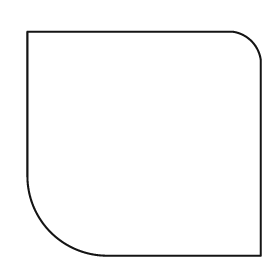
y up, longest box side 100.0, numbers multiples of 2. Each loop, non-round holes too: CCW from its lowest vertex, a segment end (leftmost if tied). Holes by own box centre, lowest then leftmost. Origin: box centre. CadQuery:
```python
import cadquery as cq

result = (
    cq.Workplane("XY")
    .moveTo(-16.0, -48.0)
    .lineTo(50.0, -48.0)
    .lineTo(50.0, 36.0)
    .threePointArc((46.0, 44.0), (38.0, 48.0))
    .lineTo(-50.0, 48.0)
    .lineTo(-50.0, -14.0)
    .threePointArc((-40.0, -38.0), (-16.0, -48.0))
    .close()
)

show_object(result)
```